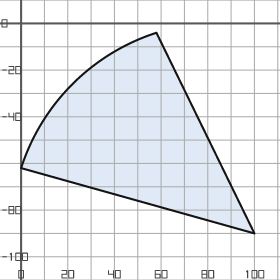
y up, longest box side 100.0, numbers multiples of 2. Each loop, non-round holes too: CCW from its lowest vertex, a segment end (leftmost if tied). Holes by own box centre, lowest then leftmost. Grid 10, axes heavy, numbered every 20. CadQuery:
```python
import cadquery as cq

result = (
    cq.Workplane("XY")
    .moveTo(100.0, -90.0)
    .lineTo(58.0, -4.0)
    .threePointArc((22.0, -26.0), (0.0, -62.0))
    .close()
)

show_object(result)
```